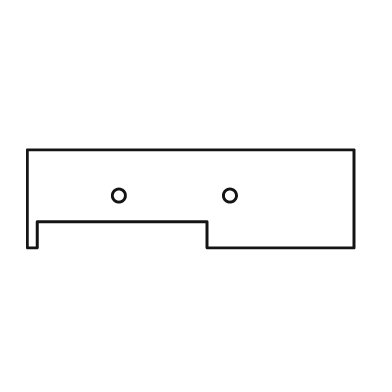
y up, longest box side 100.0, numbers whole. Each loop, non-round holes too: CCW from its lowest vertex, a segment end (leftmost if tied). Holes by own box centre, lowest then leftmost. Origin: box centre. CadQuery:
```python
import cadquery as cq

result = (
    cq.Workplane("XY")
    .moveTo(-50.0, -15.0)
    .lineTo(-47.0, -15.0)
    .lineTo(-47.0, -7.0)
    .lineTo(5.0, -7.0)
    .lineTo(5.0, -15.0)
    .lineTo(50.0, -15.0)
    .lineTo(50.0, 15.0)
    .lineTo(-50.0, 15.0)
    .close()
    .moveTo(-22.0, 1.0)
    .circle(2.0)
    .moveTo(12.0, 1.0)
    .circle(2.0)
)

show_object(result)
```